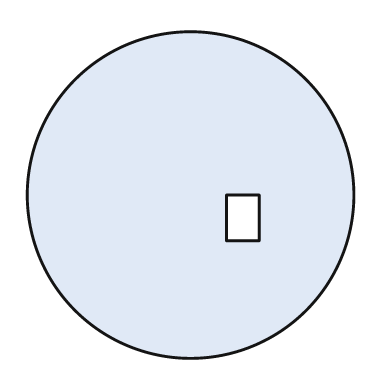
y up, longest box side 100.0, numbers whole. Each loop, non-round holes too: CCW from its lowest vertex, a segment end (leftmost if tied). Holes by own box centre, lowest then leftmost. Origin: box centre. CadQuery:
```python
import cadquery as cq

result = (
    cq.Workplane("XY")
    .moveTo(0.0, 0.0)
    .circle(50.0)
    .moveTo(11.0, -14.0)
    .lineTo(21.0, -14.0)
    .lineTo(21.0, 0.0)
    .lineTo(11.0, 0.0)
    .close()
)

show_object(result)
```